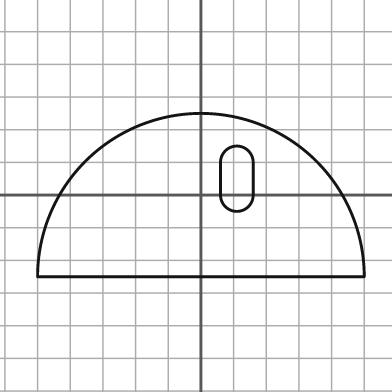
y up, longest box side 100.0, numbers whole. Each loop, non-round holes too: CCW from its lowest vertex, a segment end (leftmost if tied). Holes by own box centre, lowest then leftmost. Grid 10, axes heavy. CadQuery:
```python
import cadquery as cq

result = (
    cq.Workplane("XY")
    .moveTo(-50.0, -25.0)
    .lineTo(50.0, -25.0)
    .threePointArc((0.0, 25.0), (-50.0, -25.0))
    .close()
    .moveTo(6.0, 0.0)
    .threePointArc((11.0, -5.0), (16.0, 0.0))
    .lineTo(16.0, 10.0)
    .threePointArc((11.0, 15.0), (6.0, 10.0))
    .close()
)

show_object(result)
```